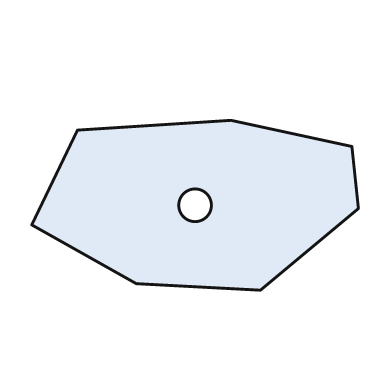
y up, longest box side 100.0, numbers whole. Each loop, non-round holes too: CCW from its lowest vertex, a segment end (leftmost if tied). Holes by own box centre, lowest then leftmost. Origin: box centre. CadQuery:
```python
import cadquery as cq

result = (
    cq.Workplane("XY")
    .moveTo(20.0, -26.0)
    .lineTo(50.0, -1.0)
    .lineTo(48.0, 18.0)
    .lineTo(11.0, 26.0)
    .lineTo(-36.0, 23.0)
    .lineTo(-50.0, -6.0)
    .lineTo(-18.0, -24.0)
    .close()
    .moveTo(0.0, 0.0)
    .circle(5.0)
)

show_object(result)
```